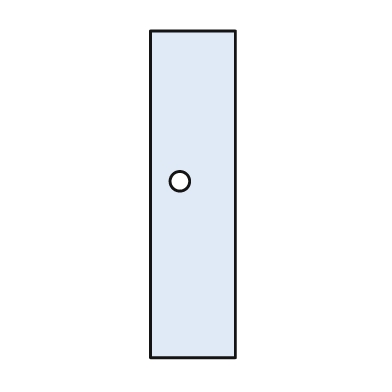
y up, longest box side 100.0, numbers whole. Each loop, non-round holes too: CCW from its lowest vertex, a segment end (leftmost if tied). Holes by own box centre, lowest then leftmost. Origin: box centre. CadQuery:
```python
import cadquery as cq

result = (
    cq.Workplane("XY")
    .moveTo(-13.0, -50.0)
    .lineTo(13.0, -50.0)
    .lineTo(13.0, 50.0)
    .lineTo(-13.0, 50.0)
    .close()
    .moveTo(-4.0, 4.0)
    .circle(3.0)
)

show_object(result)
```